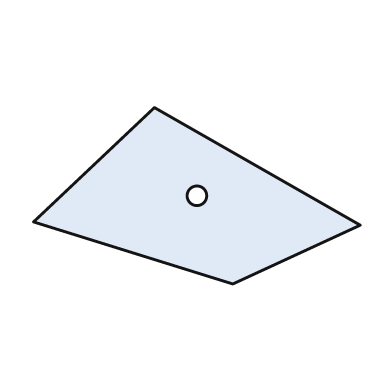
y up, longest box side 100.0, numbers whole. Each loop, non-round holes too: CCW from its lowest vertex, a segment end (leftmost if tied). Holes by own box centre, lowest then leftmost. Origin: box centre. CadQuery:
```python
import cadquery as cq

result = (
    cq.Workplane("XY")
    .moveTo(11.0, -27.0)
    .lineTo(50.0, -9.0)
    .lineTo(-13.0, 27.0)
    .lineTo(-50.0, -8.0)
    .close()
    .moveTo(0.0, 0.0)
    .circle(3.0)
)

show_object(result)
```